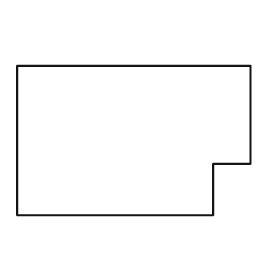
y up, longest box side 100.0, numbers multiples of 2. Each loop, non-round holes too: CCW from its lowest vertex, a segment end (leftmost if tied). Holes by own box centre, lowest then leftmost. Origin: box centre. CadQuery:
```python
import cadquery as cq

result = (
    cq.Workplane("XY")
    .moveTo(-50.0, -32.0)
    .lineTo(34.0, -32.0)
    .lineTo(34.0, -10.0)
    .lineTo(50.0, -10.0)
    .lineTo(50.0, 32.0)
    .lineTo(-50.0, 32.0)
    .close()
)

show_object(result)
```